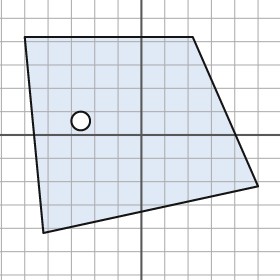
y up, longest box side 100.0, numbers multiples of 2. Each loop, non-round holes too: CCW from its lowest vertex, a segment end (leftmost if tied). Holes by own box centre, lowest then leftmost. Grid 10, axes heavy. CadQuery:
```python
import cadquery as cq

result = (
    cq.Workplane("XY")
    .moveTo(-42.0, -42.0)
    .lineTo(50.0, -22.0)
    .lineTo(22.0, 42.0)
    .lineTo(-50.0, 42.0)
    .close()
    .moveTo(-26.0, 6.0)
    .circle(4.0)
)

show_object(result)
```